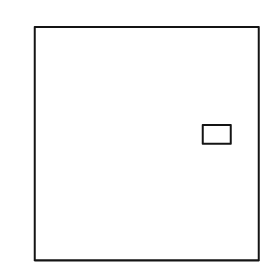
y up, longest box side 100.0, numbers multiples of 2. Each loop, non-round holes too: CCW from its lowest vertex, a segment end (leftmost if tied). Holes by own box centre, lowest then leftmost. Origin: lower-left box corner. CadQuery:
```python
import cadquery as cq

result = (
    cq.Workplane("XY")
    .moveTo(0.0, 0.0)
    .lineTo(96.0, 0.0)
    .lineTo(96.0, 100.0)
    .lineTo(0.0, 100.0)
    .close()
    .moveTo(72.0, 50.0)
    .lineTo(84.0, 50.0)
    .lineTo(84.0, 58.0)
    .lineTo(72.0, 58.0)
    .close()
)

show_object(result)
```